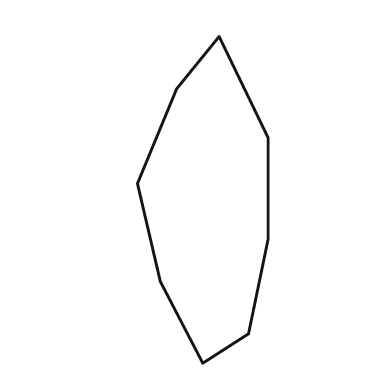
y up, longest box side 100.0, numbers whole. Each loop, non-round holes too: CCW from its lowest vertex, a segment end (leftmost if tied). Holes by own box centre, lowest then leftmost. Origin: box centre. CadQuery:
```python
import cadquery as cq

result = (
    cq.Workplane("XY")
    .moveTo(0.0, -50.0)
    .lineTo(14.0, -41.0)
    .lineTo(20.0, -12.0)
    .lineTo(20.0, 19.0)
    .lineTo(5.0, 50.0)
    .lineTo(-8.0, 34.0)
    .lineTo(-20.0, 5.0)
    .lineTo(-13.0, -25.0)
    .close()
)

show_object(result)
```